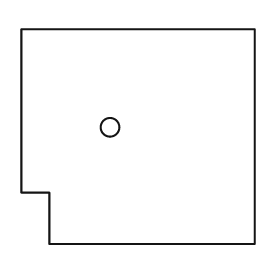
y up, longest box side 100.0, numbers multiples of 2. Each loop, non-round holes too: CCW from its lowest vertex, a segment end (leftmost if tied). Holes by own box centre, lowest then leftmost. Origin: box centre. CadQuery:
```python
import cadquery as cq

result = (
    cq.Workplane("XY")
    .moveTo(-38.0, -46.0)
    .lineTo(50.0, -46.0)
    .lineTo(50.0, 46.0)
    .lineTo(-50.0, 46.0)
    .lineTo(-50.0, -24.0)
    .lineTo(-38.0, -24.0)
    .close()
    .moveTo(-12.0, 4.0)
    .circle(4.0)
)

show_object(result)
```